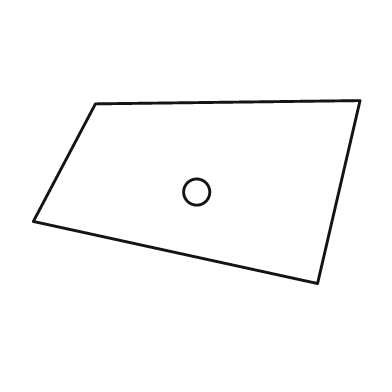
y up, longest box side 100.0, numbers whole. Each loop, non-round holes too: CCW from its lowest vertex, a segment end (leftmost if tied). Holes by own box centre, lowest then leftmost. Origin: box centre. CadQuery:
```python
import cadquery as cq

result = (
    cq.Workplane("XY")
    .moveTo(37.0, -28.0)
    .lineTo(50.0, 28.0)
    .lineTo(-31.0, 27.0)
    .lineTo(-50.0, -9.0)
    .close()
    .moveTo(0.0, 0.0)
    .circle(4.0)
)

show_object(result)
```